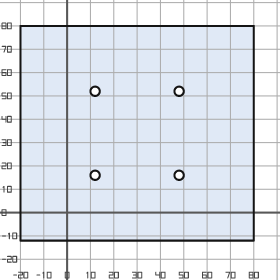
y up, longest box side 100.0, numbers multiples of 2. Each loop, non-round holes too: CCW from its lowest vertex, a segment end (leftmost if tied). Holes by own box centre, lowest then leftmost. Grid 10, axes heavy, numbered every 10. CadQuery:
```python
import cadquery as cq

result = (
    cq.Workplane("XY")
    .moveTo(-20.0, -12.0)
    .lineTo(80.0, -12.0)
    .lineTo(80.0, 80.0)
    .lineTo(-20.0, 80.0)
    .close()
    .moveTo(12.0, 16.0)
    .circle(2.0)
    .moveTo(48.0, 16.0)
    .circle(2.0)
    .moveTo(12.0, 52.0)
    .circle(2.0)
    .moveTo(48.0, 52.0)
    .circle(2.0)
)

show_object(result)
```